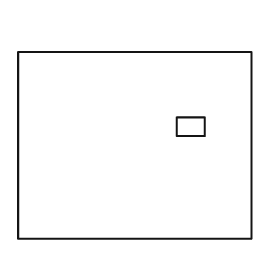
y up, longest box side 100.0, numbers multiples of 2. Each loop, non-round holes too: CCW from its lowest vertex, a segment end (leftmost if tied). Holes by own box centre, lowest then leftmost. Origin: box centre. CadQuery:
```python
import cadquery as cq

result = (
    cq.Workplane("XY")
    .moveTo(-50.0, -40.0)
    .lineTo(50.0, -40.0)
    .lineTo(50.0, 40.0)
    .lineTo(-50.0, 40.0)
    .close()
    .moveTo(18.0, 4.0)
    .lineTo(30.0, 4.0)
    .lineTo(30.0, 12.0)
    .lineTo(18.0, 12.0)
    .close()
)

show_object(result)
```